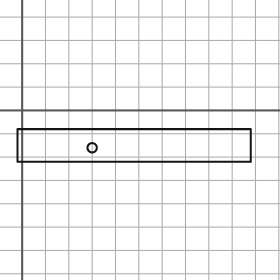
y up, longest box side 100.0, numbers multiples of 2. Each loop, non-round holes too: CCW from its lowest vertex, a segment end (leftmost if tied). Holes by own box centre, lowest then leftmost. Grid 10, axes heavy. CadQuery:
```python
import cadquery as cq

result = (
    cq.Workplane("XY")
    .moveTo(-2.0, -22.0)
    .lineTo(98.0, -22.0)
    .lineTo(98.0, -8.0)
    .lineTo(-2.0, -8.0)
    .close()
    .moveTo(30.0, -16.0)
    .circle(2.0)
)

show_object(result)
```